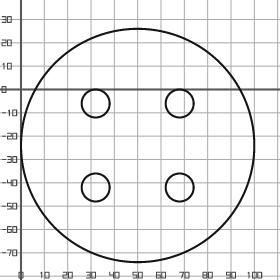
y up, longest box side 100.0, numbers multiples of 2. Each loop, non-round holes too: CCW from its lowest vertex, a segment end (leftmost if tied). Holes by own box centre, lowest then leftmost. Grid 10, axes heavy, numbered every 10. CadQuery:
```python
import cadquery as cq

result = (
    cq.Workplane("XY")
    .moveTo(50.0, -24.0)
    .circle(50.0)
    .moveTo(32.0, -42.0)
    .circle(6.0)
    .moveTo(68.0, -42.0)
    .circle(6.0)
    .moveTo(32.0, -6.0)
    .circle(6.0)
    .moveTo(68.0, -6.0)
    .circle(6.0)
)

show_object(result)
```